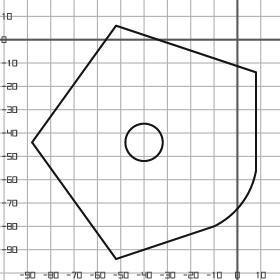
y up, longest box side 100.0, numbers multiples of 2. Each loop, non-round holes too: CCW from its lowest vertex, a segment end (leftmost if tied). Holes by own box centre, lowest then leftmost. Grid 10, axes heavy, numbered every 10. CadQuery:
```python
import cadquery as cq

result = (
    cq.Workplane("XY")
    .moveTo(-52.0, -94.0)
    .lineTo(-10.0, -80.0)
    .threePointArc((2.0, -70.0), (8.0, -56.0))
    .lineTo(8.0, -14.0)
    .lineTo(-52.0, 6.0)
    .lineTo(-88.0, -44.0)
    .close()
    .moveTo(-40.0, -44.0)
    .circle(8.0)
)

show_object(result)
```